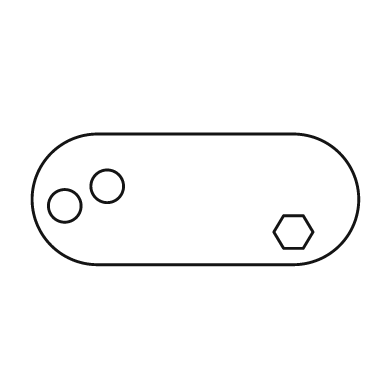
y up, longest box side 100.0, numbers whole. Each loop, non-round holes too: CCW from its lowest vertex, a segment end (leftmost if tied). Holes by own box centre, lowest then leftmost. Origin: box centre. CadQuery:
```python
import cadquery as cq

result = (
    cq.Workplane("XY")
    .moveTo(-30.0, -20.0)
    .lineTo(30.0, -20.0)
    .threePointArc((50.0, 0.0), (30.0, 20.0))
    .lineTo(-30.0, 20.0)
    .threePointArc((-50.0, 0.0), (-30.0, -20.0))
    .close()
    .moveTo(27.0, -15.0)
    .lineTo(33.0, -15.0)
    .lineTo(36.0, -10.0)
    .lineTo(33.0, -5.0)
    .lineTo(27.0, -5.0)
    .lineTo(24.0, -10.0)
    .close()
    .moveTo(-40.0, -2.0)
    .circle(5.0)
    .moveTo(-27.0, 4.0)
    .circle(5.0)
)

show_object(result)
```